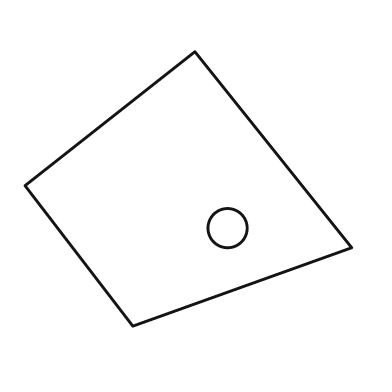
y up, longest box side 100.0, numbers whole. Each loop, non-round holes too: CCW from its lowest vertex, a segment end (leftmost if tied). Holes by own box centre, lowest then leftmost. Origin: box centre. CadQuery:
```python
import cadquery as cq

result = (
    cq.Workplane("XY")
    .moveTo(-17.0, -42.0)
    .lineTo(50.0, -18.0)
    .lineTo(2.0, 42.0)
    .lineTo(-50.0, 1.0)
    .close()
    .moveTo(12.0, -12.0)
    .circle(6.0)
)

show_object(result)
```